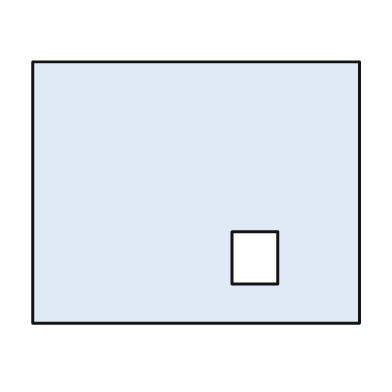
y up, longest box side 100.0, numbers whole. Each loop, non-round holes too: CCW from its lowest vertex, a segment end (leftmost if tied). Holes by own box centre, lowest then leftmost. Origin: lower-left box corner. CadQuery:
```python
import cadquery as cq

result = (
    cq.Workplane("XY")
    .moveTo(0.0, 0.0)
    .lineTo(100.0, 0.0)
    .lineTo(100.0, 80.0)
    .lineTo(0.0, 80.0)
    .close()
    .moveTo(61.0, 12.0)
    .lineTo(75.0, 12.0)
    .lineTo(75.0, 28.0)
    .lineTo(61.0, 28.0)
    .close()
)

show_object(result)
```